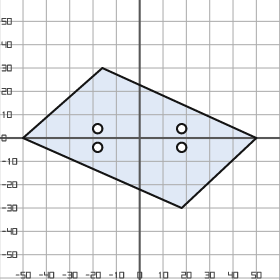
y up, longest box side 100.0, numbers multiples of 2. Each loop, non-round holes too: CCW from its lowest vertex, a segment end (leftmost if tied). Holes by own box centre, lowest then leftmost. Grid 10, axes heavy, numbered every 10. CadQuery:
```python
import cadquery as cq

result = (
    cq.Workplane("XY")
    .moveTo(18.0, -30.0)
    .lineTo(50.0, 0.0)
    .lineTo(-16.0, 30.0)
    .lineTo(-50.0, 0.0)
    .close()
    .moveTo(-18.0, -4.0)
    .circle(2.0)
    .moveTo(18.0, -4.0)
    .circle(2.0)
    .moveTo(-18.0, 4.0)
    .circle(2.0)
    .moveTo(18.0, 4.0)
    .circle(2.0)
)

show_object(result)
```